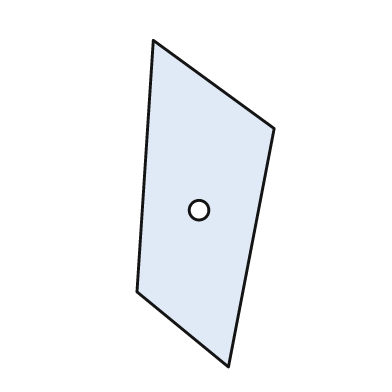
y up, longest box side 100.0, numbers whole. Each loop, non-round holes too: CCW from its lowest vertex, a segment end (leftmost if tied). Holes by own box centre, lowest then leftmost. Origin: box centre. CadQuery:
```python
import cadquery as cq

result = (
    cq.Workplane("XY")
    .moveTo(7.0, -50.0)
    .lineTo(21.0, 23.0)
    .lineTo(-16.0, 50.0)
    .lineTo(-21.0, -27.0)
    .close()
    .moveTo(-2.0, -2.0)
    .circle(3.0)
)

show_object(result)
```